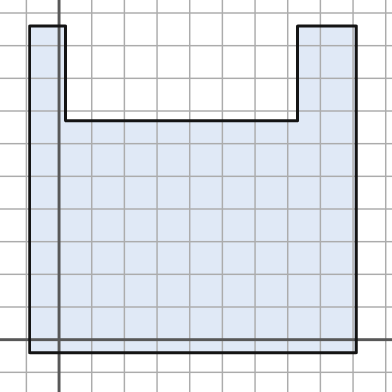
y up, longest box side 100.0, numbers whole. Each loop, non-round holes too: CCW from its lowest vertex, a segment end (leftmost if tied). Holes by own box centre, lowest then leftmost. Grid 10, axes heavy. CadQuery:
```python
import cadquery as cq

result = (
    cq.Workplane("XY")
    .moveTo(-9.0, -4.0)
    .lineTo(91.0, -4.0)
    .lineTo(91.0, 96.0)
    .lineTo(73.0, 96.0)
    .lineTo(73.0, 67.0)
    .lineTo(2.0, 67.0)
    .lineTo(2.0, 96.0)
    .lineTo(-9.0, 96.0)
    .close()
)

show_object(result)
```